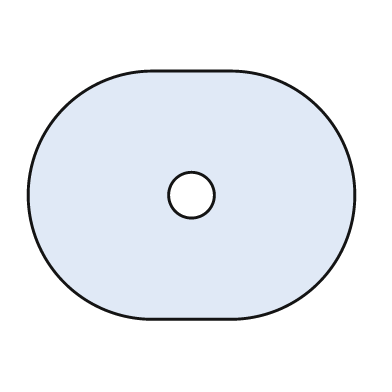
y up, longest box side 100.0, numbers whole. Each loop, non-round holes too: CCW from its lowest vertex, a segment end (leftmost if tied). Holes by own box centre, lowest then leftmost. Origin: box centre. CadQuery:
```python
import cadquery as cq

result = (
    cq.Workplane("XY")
    .moveTo(-12.0, -38.0)
    .lineTo(12.0, -38.0)
    .threePointArc((50.0, 0.0), (12.0, 38.0))
    .lineTo(-12.0, 38.0)
    .threePointArc((-50.0, 0.0), (-12.0, -38.0))
    .close()
    .moveTo(0.0, 0.0)
    .circle(7.0)
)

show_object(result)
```